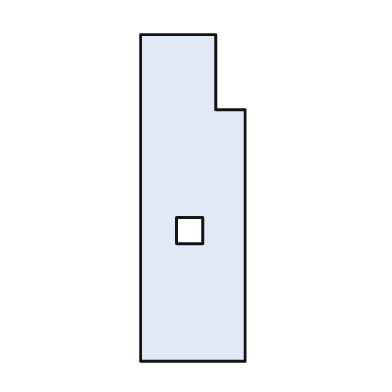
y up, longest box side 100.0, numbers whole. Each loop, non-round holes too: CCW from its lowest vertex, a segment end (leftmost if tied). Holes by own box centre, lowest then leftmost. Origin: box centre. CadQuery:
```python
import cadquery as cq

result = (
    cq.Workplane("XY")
    .moveTo(-16.0, -50.0)
    .lineTo(16.0, -50.0)
    .lineTo(16.0, 27.0)
    .lineTo(7.0, 27.0)
    .lineTo(7.0, 50.0)
    .lineTo(-16.0, 50.0)
    .close()
    .moveTo(-5.0, -14.0)
    .lineTo(3.0, -14.0)
    .lineTo(3.0, -6.0)
    .lineTo(-5.0, -6.0)
    .close()
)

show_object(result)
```